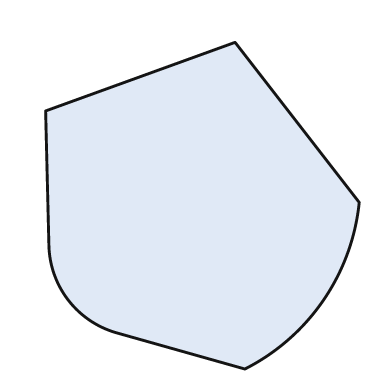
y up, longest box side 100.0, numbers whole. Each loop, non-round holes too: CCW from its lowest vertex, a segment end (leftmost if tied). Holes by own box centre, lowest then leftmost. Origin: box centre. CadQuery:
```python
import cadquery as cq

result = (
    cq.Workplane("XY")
    .moveTo(13.0, -50.0)
    .threePointArc((37.0, -29.0), (48.0, 1.0))
    .lineTo(10.0, 50.0)
    .lineTo(-48.0, 29.0)
    .lineTo(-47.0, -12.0)
    .threePointArc((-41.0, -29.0), (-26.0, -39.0))
    .close()
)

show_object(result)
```